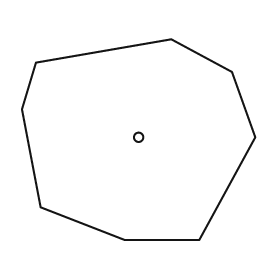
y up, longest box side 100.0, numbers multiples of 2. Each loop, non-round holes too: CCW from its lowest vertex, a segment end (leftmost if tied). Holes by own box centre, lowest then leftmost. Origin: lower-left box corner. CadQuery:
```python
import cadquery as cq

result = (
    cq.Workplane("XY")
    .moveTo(44.0, 0.0)
    .lineTo(76.0, 0.0)
    .lineTo(100.0, 44.0)
    .lineTo(90.0, 72.0)
    .lineTo(64.0, 86.0)
    .lineTo(6.0, 76.0)
    .lineTo(0.0, 56.0)
    .lineTo(8.0, 14.0)
    .close()
    .moveTo(50.0, 44.0)
    .circle(2.0)
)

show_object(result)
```